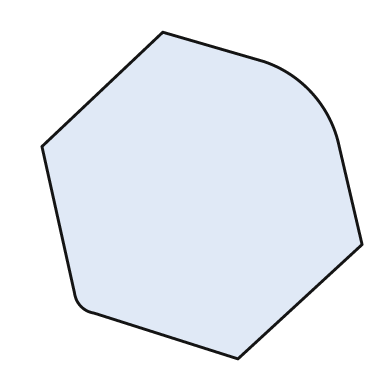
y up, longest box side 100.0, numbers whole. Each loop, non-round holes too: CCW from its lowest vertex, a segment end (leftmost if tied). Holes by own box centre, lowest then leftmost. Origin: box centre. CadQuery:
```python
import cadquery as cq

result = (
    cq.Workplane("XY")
    .moveTo(11.0, -50.0)
    .lineTo(49.0, -15.0)
    .lineTo(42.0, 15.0)
    .threePointArc((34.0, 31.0), (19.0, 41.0))
    .lineTo(-12.0, 50.0)
    .lineTo(-49.0, 15.0)
    .lineTo(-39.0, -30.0)
    .threePointArc((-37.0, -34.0), (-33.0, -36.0))
    .close()
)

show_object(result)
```